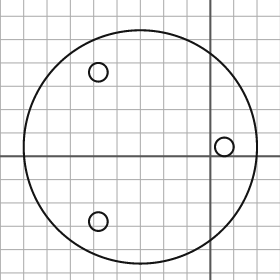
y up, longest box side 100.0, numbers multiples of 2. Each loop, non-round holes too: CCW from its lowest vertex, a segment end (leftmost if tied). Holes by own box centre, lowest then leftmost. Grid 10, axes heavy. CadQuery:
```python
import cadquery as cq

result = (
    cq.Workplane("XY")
    .moveTo(-30.0, 4.0)
    .circle(50.0)
    .moveTo(-48.0, -28.0)
    .circle(4.0)
    .moveTo(6.0, 4.0)
    .circle(4.0)
    .moveTo(-48.0, 36.0)
    .circle(4.0)
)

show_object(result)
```